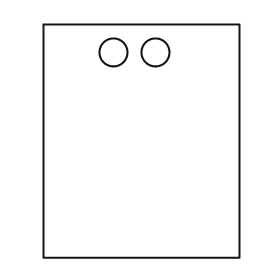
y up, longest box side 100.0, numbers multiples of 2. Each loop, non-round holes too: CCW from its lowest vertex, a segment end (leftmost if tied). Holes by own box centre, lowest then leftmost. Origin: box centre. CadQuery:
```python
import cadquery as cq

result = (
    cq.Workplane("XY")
    .moveTo(-42.0, -50.0)
    .lineTo(42.0, -50.0)
    .lineTo(42.0, 50.0)
    .lineTo(-42.0, 50.0)
    .close()
    .moveTo(-12.0, 38.0)
    .circle(6.0)
    .moveTo(6.0, 38.0)
    .circle(6.0)
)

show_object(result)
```